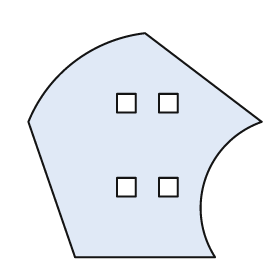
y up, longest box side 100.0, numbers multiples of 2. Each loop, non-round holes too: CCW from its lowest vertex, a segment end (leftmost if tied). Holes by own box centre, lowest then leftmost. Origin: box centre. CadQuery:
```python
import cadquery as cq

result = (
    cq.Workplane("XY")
    .moveTo(-30.0, -48.0)
    .lineTo(30.0, -48.0)
    .threePointArc((26.0, -14.0), (50.0, 10.0))
    .lineTo(0.0, 48.0)
    .threePointArc((-30.0, 36.0), (-50.0, 10.0))
    .close()
    .moveTo(-12.0, -22.0)
    .lineTo(-4.0, -22.0)
    .lineTo(-4.0, -14.0)
    .lineTo(-12.0, -14.0)
    .close()
    .moveTo(6.0, -22.0)
    .lineTo(14.0, -22.0)
    .lineTo(14.0, -14.0)
    .lineTo(6.0, -14.0)
    .close()
    .moveTo(-12.0, 14.0)
    .lineTo(-4.0, 14.0)
    .lineTo(-4.0, 22.0)
    .lineTo(-12.0, 22.0)
    .close()
    .moveTo(6.0, 14.0)
    .lineTo(14.0, 14.0)
    .lineTo(14.0, 22.0)
    .lineTo(6.0, 22.0)
    .close()
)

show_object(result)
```